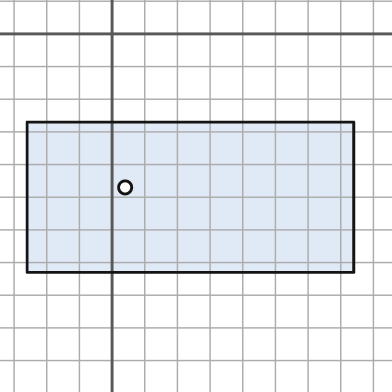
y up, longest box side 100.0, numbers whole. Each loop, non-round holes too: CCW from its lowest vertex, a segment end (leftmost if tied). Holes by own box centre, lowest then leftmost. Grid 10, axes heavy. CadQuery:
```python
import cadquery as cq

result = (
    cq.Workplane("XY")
    .moveTo(-26.0, -73.0)
    .lineTo(74.0, -73.0)
    .lineTo(74.0, -27.0)
    .lineTo(-26.0, -27.0)
    .close()
    .moveTo(4.0, -47.0)
    .circle(2.0)
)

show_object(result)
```